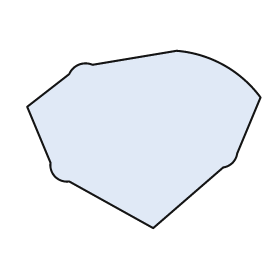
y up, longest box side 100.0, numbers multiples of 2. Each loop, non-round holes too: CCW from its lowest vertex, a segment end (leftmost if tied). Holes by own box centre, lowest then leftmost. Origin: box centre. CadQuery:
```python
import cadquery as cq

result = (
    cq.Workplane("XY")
    .moveTo(4.0, -38.0)
    .lineTo(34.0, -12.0)
    .threePointArc((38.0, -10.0), (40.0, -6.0))
    .lineTo(50.0, 18.0)
    .threePointArc((34.0, 32.0), (14.0, 38.0))
    .lineTo(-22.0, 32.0)
    .threePointArc((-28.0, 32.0), (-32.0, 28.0))
    .lineTo(-50.0, 14.0)
    .lineTo(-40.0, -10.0)
    .threePointArc((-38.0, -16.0), (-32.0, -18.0))
    .close()
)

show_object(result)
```